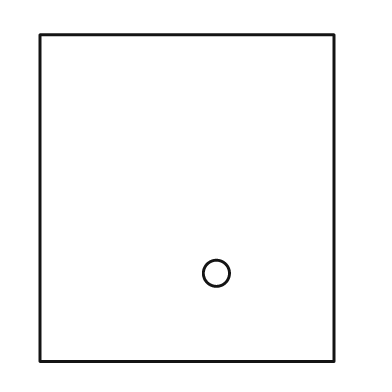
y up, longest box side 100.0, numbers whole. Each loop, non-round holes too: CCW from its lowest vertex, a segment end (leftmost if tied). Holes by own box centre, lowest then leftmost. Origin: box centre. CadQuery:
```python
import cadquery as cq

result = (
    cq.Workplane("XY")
    .moveTo(-45.0, -50.0)
    .lineTo(45.0, -50.0)
    .lineTo(45.0, 50.0)
    .lineTo(-45.0, 50.0)
    .close()
    .moveTo(9.0, -23.0)
    .circle(4.0)
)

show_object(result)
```